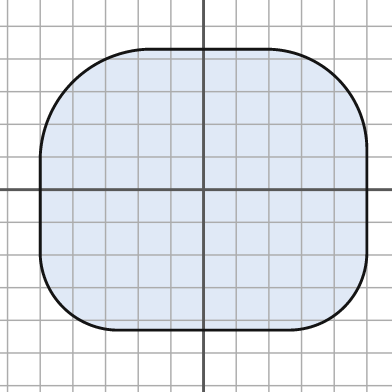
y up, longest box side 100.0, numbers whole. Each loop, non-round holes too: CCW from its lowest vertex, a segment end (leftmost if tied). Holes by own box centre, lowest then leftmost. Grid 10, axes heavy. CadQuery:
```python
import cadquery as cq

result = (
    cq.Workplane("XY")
    .moveTo(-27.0, -43.0)
    .lineTo(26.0, -43.0)
    .threePointArc((43.0, -36.0), (50.0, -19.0))
    .lineTo(50.0, 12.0)
    .threePointArc((41.0, 34.0), (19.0, 43.0))
    .lineTo(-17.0, 43.0)
    .threePointArc((-40.0, 33.0), (-50.0, 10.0))
    .lineTo(-50.0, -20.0)
    .threePointArc((-43.0, -36.0), (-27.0, -43.0))
    .close()
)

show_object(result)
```